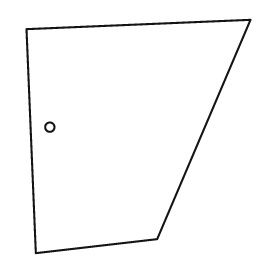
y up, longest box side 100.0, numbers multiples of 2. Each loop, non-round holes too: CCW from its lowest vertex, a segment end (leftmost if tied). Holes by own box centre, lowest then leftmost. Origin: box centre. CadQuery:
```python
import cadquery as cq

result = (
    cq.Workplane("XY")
    .moveTo(-44.0, -50.0)
    .lineTo(8.0, -44.0)
    .lineTo(48.0, 50.0)
    .lineTo(-48.0, 46.0)
    .close()
    .moveTo(-38.0, 4.0)
    .circle(2.0)
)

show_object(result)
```